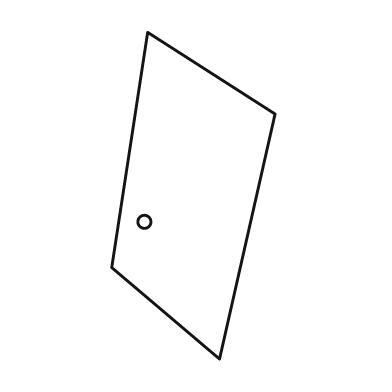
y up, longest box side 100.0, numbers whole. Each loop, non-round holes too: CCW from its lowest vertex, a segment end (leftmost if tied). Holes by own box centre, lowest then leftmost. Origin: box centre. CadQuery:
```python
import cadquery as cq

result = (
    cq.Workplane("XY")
    .moveTo(8.0, -50.0)
    .lineTo(25.0, 25.0)
    .lineTo(-14.0, 50.0)
    .lineTo(-25.0, -22.0)
    .close()
    .moveTo(-15.0, -8.0)
    .circle(2.0)
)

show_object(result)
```